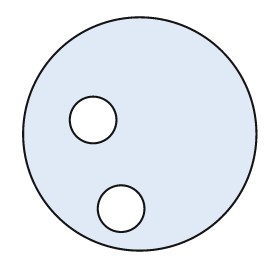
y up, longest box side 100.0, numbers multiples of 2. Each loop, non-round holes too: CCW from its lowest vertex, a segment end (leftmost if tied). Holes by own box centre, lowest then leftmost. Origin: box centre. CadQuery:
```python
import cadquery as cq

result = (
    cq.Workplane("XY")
    .moveTo(0.0, 0.0)
    .circle(50.0)
    .moveTo(-8.0, -32.0)
    .circle(10.0)
    .moveTo(-20.0, 6.0)
    .circle(10.0)
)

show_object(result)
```